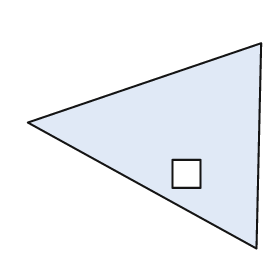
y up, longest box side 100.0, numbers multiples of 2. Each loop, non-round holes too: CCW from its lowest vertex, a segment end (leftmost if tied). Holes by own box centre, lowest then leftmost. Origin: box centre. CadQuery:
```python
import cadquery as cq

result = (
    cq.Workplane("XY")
    .moveTo(48.0, -44.0)
    .lineTo(50.0, 44.0)
    .lineTo(-50.0, 10.0)
    .close()
    .moveTo(12.0, -18.0)
    .lineTo(24.0, -18.0)
    .lineTo(24.0, -6.0)
    .lineTo(12.0, -6.0)
    .close()
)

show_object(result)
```